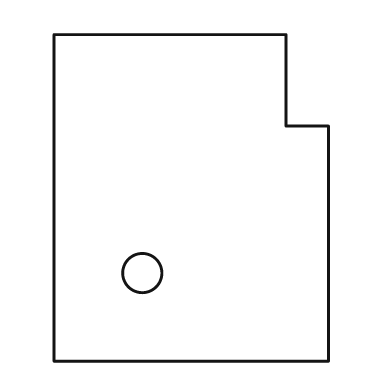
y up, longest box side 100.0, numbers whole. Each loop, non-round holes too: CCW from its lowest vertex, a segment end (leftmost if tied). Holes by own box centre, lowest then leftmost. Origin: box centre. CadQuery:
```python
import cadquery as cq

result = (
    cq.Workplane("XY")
    .moveTo(-42.0, -50.0)
    .lineTo(42.0, -50.0)
    .lineTo(42.0, 22.0)
    .lineTo(29.0, 22.0)
    .lineTo(29.0, 50.0)
    .lineTo(-42.0, 50.0)
    .close()
    .moveTo(-15.0, -23.0)
    .circle(6.0)
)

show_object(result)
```